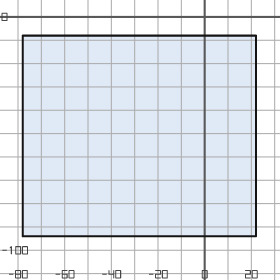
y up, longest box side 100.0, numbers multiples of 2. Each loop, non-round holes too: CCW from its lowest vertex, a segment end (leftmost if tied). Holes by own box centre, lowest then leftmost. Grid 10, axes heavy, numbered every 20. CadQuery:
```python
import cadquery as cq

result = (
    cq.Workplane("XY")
    .moveTo(-78.0, -94.0)
    .lineTo(22.0, -94.0)
    .lineTo(22.0, -8.0)
    .lineTo(-78.0, -8.0)
    .close()
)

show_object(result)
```